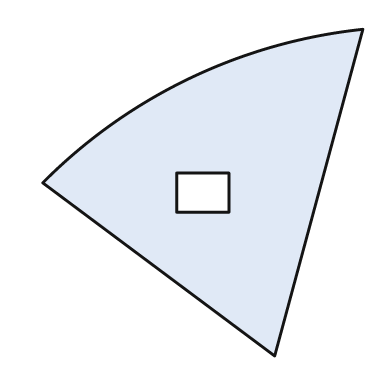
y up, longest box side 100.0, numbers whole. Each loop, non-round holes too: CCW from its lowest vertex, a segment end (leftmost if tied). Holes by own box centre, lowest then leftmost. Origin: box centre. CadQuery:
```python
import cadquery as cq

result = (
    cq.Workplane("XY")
    .moveTo(22.0, -50.0)
    .lineTo(49.0, 50.0)
    .threePointArc((-4.0, 35.0), (-49.0, 3.0))
    .close()
    .moveTo(-8.0, -6.0)
    .lineTo(8.0, -6.0)
    .lineTo(8.0, 6.0)
    .lineTo(-8.0, 6.0)
    .close()
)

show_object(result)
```